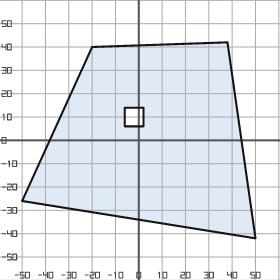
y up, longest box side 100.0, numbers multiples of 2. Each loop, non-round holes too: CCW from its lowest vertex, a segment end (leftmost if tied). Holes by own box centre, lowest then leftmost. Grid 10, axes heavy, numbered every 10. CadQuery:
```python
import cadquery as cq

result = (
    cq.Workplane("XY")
    .moveTo(50.0, -42.0)
    .lineTo(38.0, 42.0)
    .lineTo(-20.0, 40.0)
    .lineTo(-50.0, -26.0)
    .close()
    .moveTo(-6.0, 6.0)
    .lineTo(2.0, 6.0)
    .lineTo(2.0, 14.0)
    .lineTo(-6.0, 14.0)
    .close()
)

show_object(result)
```